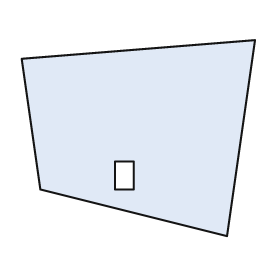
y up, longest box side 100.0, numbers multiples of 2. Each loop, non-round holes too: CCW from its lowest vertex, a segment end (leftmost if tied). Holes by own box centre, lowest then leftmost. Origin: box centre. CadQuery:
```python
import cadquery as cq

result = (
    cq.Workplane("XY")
    .moveTo(38.0, -42.0)
    .lineTo(50.0, 42.0)
    .lineTo(-50.0, 34.0)
    .lineTo(-42.0, -22.0)
    .close()
    .moveTo(-10.0, -22.0)
    .lineTo(-2.0, -22.0)
    .lineTo(-2.0, -10.0)
    .lineTo(-10.0, -10.0)
    .close()
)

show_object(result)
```